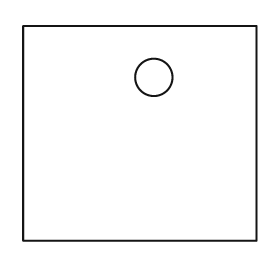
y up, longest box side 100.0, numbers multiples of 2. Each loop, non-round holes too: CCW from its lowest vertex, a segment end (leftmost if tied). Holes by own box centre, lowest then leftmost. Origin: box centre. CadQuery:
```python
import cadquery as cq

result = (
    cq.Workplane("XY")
    .moveTo(-50.0, -46.0)
    .lineTo(50.0, -46.0)
    .lineTo(50.0, 46.0)
    .lineTo(-50.0, 46.0)
    .close()
    .moveTo(6.0, 24.0)
    .circle(8.0)
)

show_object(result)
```